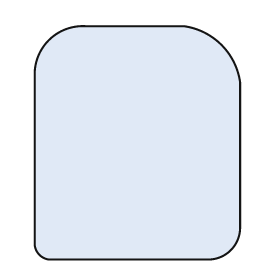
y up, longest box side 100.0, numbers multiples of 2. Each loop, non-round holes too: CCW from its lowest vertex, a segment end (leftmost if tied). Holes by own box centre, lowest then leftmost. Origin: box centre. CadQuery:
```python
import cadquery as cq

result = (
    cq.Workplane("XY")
    .moveTo(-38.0, -50.0)
    .lineTo(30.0, -50.0)
    .threePointArc((40.0, -46.0), (44.0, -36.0))
    .lineTo(44.0, 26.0)
    .threePointArc((36.0, 42.0), (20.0, 50.0))
    .lineTo(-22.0, 50.0)
    .threePointArc((-38.0, 44.0), (-44.0, 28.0))
    .lineTo(-44.0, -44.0)
    .threePointArc((-42.0, -48.0), (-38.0, -50.0))
    .close()
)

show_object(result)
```